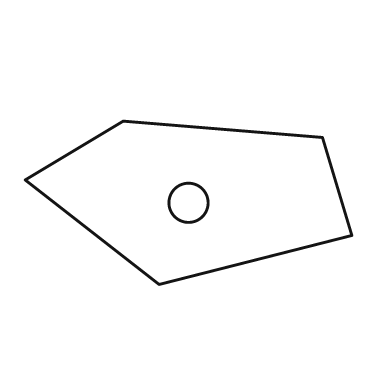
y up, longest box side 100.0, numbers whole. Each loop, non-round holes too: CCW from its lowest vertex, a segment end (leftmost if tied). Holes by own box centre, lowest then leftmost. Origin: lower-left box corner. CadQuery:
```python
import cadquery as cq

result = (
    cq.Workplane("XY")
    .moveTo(41.0, 0.0)
    .lineTo(100.0, 15.0)
    .lineTo(91.0, 45.0)
    .lineTo(30.0, 50.0)
    .lineTo(0.0, 32.0)
    .close()
    .moveTo(50.0, 25.0)
    .circle(6.0)
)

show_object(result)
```